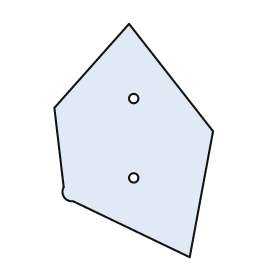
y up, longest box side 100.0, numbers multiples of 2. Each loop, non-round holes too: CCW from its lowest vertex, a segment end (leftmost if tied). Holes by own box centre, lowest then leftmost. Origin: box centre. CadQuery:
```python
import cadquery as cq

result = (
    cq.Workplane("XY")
    .moveTo(24.0, -50.0)
    .lineTo(34.0, 4.0)
    .lineTo(-2.0, 50.0)
    .lineTo(-34.0, 14.0)
    .lineTo(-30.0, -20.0)
    .threePointArc((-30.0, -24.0), (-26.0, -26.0))
    .close()
    .moveTo(0.0, -16.0)
    .circle(2.0)
    .moveTo(0.0, 18.0)
    .circle(2.0)
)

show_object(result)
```